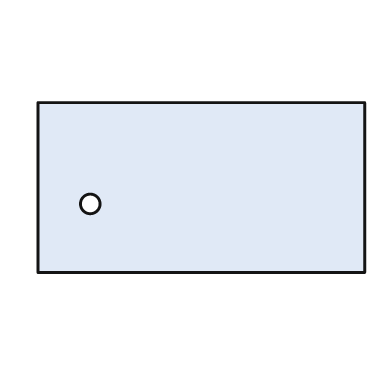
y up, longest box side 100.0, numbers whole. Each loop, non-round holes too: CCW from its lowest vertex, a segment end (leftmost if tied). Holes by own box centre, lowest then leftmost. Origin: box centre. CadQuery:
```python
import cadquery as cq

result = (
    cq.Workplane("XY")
    .moveTo(-50.0, -26.0)
    .lineTo(50.0, -26.0)
    .lineTo(50.0, 26.0)
    .lineTo(-50.0, 26.0)
    .close()
    .moveTo(-34.0, -5.0)
    .circle(3.0)
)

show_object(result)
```